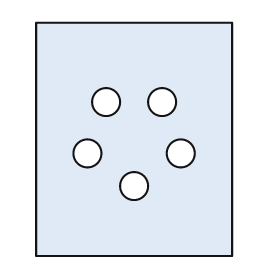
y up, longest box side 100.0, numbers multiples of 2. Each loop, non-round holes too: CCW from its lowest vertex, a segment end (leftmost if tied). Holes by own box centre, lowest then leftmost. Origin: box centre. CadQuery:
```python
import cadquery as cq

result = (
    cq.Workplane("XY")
    .moveTo(-42.0, -50.0)
    .lineTo(42.0, -50.0)
    .lineTo(42.0, 50.0)
    .lineTo(-42.0, 50.0)
    .close()
    .moveTo(0.0, -20.0)
    .circle(6.0)
    .moveTo(-20.0, -6.0)
    .circle(6.0)
    .moveTo(20.0, -6.0)
    .circle(6.0)
    .moveTo(-12.0, 16.0)
    .circle(6.0)
    .moveTo(12.0, 16.0)
    .circle(6.0)
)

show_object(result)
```